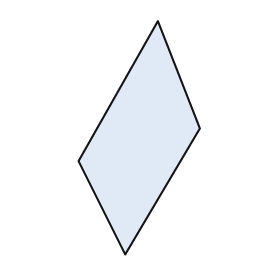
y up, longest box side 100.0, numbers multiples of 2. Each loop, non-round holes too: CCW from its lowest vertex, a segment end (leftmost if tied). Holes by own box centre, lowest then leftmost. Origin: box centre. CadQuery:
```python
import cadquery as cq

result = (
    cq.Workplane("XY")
    .moveTo(-6.0, -50.0)
    .lineTo(26.0, 4.0)
    .lineTo(8.0, 50.0)
    .lineTo(-26.0, -10.0)
    .close()
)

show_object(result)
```